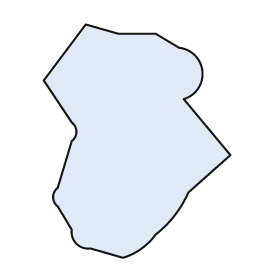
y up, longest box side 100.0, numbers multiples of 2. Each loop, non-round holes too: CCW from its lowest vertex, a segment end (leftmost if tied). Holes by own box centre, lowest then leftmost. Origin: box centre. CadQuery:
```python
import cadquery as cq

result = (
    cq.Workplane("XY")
    .moveTo(-6.0, -50.0)
    .threePointArc((2.0, -46.0), (8.0, -40.0))
    .threePointArc((16.0, -32.0), (22.0, -22.0))
    .lineTo(40.0, -6.0)
    .lineTo(20.0, 18.0)
    .threePointArc((28.0, 30.0), (18.0, 40.0))
    .lineTo(8.0, 46.0)
    .lineTo(-8.0, 46.0)
    .lineTo(-22.0, 50.0)
    .lineTo(-40.0, 26.0)
    .lineTo(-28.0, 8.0)
    .threePointArc((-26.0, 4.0), (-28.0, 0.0))
    .lineTo(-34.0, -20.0)
    .threePointArc((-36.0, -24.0), (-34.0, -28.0))
    .lineTo(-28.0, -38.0)
    .threePointArc((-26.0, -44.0), (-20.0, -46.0))
    .close()
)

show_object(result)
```